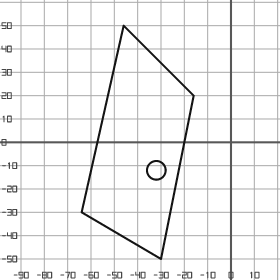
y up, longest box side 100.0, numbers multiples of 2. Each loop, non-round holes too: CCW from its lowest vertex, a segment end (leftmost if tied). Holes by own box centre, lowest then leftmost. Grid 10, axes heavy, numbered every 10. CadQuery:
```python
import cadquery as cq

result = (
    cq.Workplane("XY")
    .moveTo(-30.0, -50.0)
    .lineTo(-16.0, 20.0)
    .lineTo(-46.0, 50.0)
    .lineTo(-64.0, -30.0)
    .close()
    .moveTo(-32.0, -12.0)
    .circle(4.0)
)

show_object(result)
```